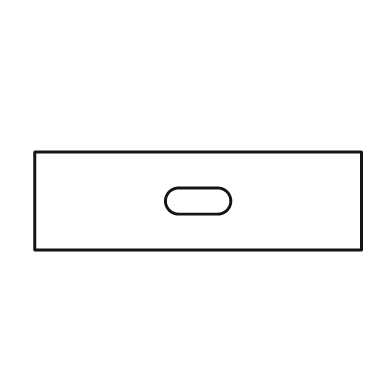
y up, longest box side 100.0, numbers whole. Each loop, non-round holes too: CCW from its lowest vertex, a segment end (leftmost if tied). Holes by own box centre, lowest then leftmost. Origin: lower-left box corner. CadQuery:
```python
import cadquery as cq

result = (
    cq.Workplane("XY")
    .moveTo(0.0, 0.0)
    .lineTo(100.0, 0.0)
    .lineTo(100.0, 30.0)
    .lineTo(0.0, 30.0)
    .close()
    .moveTo(44.0, 11.0)
    .lineTo(56.0, 11.0)
    .threePointArc((60.0, 15.0), (56.0, 19.0))
    .lineTo(44.0, 19.0)
    .threePointArc((40.0, 15.0), (44.0, 11.0))
    .close()
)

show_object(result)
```